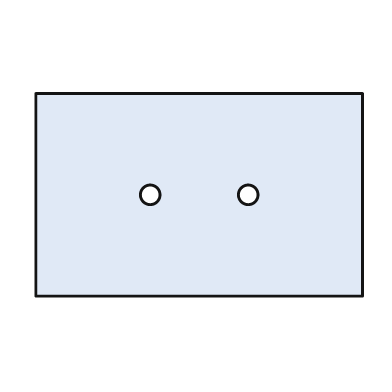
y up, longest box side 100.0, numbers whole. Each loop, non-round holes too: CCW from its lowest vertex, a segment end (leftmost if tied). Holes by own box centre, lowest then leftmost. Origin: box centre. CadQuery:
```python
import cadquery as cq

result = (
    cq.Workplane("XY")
    .moveTo(-50.0, -31.0)
    .lineTo(50.0, -31.0)
    .lineTo(50.0, 31.0)
    .lineTo(-50.0, 31.0)
    .close()
    .moveTo(-15.0, 0.0)
    .circle(3.0)
    .moveTo(15.0, 0.0)
    .circle(3.0)
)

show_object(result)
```